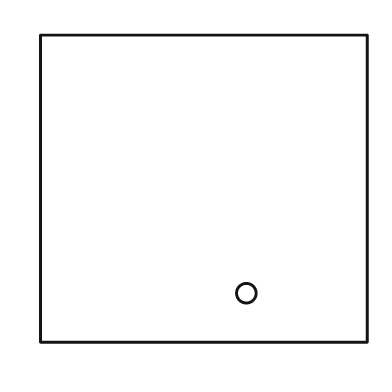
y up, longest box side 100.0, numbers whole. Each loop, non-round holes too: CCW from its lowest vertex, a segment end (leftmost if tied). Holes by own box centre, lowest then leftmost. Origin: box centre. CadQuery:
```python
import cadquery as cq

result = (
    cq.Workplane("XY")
    .moveTo(-50.0, -47.0)
    .lineTo(50.0, -47.0)
    .lineTo(50.0, 47.0)
    .lineTo(-50.0, 47.0)
    .close()
    .moveTo(13.0, -32.0)
    .circle(3.0)
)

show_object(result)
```